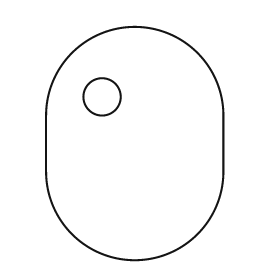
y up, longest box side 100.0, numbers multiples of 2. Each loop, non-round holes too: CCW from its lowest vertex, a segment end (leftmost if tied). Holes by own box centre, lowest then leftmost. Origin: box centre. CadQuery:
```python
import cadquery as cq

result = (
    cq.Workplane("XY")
    .moveTo(-38.0, -12.0)
    .threePointArc((0.0, -50.0), (38.0, -12.0))
    .lineTo(38.0, 12.0)
    .threePointArc((0.0, 50.0), (-38.0, 12.0))
    .close()
    .moveTo(-14.0, 20.0)
    .circle(8.0)
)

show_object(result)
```